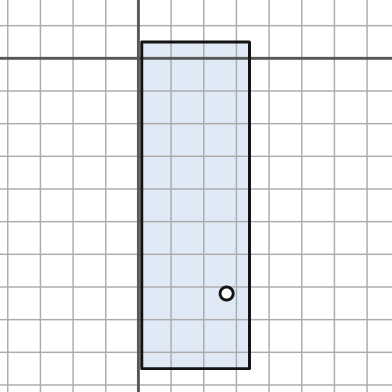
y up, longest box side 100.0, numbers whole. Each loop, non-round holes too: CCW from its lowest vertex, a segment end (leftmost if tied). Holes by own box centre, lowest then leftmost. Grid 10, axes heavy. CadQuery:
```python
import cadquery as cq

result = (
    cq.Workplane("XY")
    .moveTo(1.0, -95.0)
    .lineTo(34.0, -95.0)
    .lineTo(34.0, 5.0)
    .lineTo(1.0, 5.0)
    .close()
    .moveTo(27.0, -72.0)
    .circle(2.0)
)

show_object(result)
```